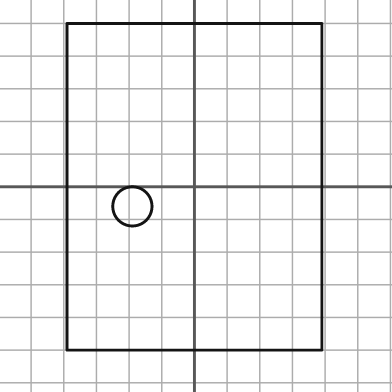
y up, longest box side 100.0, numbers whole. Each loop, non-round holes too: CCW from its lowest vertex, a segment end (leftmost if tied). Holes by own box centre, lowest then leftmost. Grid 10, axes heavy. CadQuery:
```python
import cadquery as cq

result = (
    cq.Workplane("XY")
    .moveTo(-39.0, -50.0)
    .lineTo(39.0, -50.0)
    .lineTo(39.0, 50.0)
    .lineTo(-39.0, 50.0)
    .close()
    .moveTo(-19.0, -6.0)
    .circle(6.0)
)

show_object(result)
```